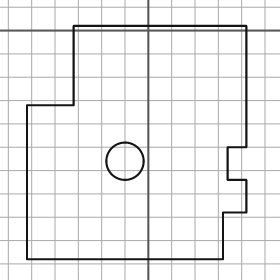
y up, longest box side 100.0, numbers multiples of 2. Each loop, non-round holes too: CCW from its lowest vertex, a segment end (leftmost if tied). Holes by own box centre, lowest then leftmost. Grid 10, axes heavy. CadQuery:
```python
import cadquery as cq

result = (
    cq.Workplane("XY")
    .moveTo(-52.0, -98.0)
    .lineTo(32.0, -98.0)
    .lineTo(32.0, -78.0)
    .lineTo(42.0, -78.0)
    .lineTo(42.0, -64.0)
    .lineTo(34.0, -64.0)
    .lineTo(34.0, -50.0)
    .lineTo(42.0, -50.0)
    .lineTo(42.0, 2.0)
    .lineTo(-32.0, 2.0)
    .lineTo(-32.0, -32.0)
    .lineTo(-52.0, -32.0)
    .close()
    .moveTo(-10.0, -56.0)
    .circle(8.0)
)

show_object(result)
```